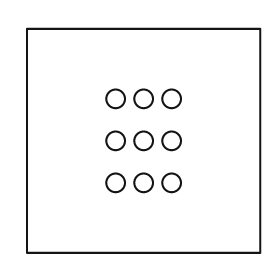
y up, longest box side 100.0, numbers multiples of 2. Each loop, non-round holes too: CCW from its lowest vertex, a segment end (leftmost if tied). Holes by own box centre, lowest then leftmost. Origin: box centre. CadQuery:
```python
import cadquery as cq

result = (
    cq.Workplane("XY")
    .moveTo(-50.0, -48.0)
    .lineTo(50.0, -48.0)
    .lineTo(50.0, 48.0)
    .lineTo(-50.0, 48.0)
    .close()
    .moveTo(-12.0, -18.0)
    .circle(4.0)
    .moveTo(0.0, -18.0)
    .circle(4.0)
    .moveTo(12.0, -18.0)
    .circle(4.0)
    .moveTo(-12.0, 0.0)
    .circle(4.0)
    .moveTo(0.0, 0.0)
    .circle(4.0)
    .moveTo(12.0, 0.0)
    .circle(4.0)
    .moveTo(-12.0, 18.0)
    .circle(4.0)
    .moveTo(0.0, 18.0)
    .circle(4.0)
    .moveTo(12.0, 18.0)
    .circle(4.0)
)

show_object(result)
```